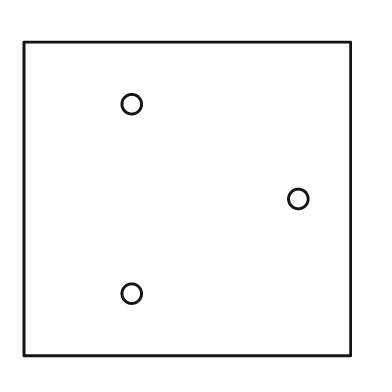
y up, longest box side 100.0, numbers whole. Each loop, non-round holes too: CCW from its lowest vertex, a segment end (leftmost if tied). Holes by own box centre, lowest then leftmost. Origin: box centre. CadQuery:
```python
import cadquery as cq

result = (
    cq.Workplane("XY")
    .moveTo(-50.0, -48.0)
    .lineTo(50.0, -48.0)
    .lineTo(50.0, 48.0)
    .lineTo(-50.0, 48.0)
    .close()
    .moveTo(-17.0, -29.0)
    .circle(3.0)
    .moveTo(34.0, 0.0)
    .circle(3.0)
    .moveTo(-17.0, 29.0)
    .circle(3.0)
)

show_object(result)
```